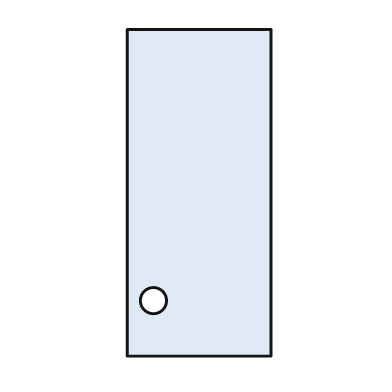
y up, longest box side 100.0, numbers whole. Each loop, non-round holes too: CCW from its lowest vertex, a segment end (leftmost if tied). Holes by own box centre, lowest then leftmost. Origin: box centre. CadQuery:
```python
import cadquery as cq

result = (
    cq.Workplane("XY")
    .moveTo(-22.0, -50.0)
    .lineTo(22.0, -50.0)
    .lineTo(22.0, 50.0)
    .lineTo(-22.0, 50.0)
    .close()
    .moveTo(-14.0, -33.0)
    .circle(4.0)
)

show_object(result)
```